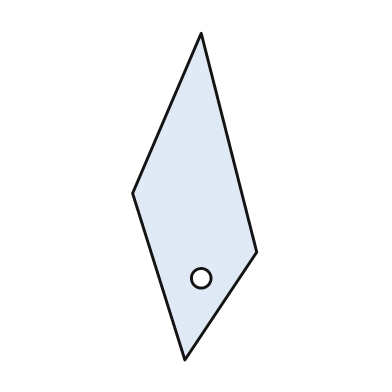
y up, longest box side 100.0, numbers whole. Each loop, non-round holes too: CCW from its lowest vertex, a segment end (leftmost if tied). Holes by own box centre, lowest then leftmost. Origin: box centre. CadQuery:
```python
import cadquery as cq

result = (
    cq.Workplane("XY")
    .moveTo(-3.0, -50.0)
    .lineTo(19.0, -17.0)
    .lineTo(2.0, 50.0)
    .lineTo(-19.0, 1.0)
    .close()
    .moveTo(2.0, -25.0)
    .circle(3.0)
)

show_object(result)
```